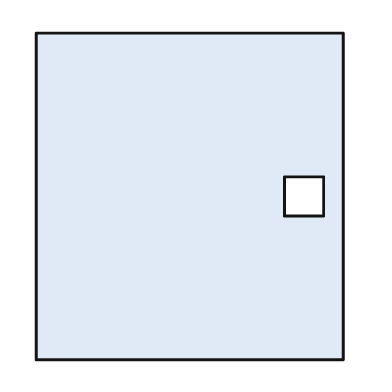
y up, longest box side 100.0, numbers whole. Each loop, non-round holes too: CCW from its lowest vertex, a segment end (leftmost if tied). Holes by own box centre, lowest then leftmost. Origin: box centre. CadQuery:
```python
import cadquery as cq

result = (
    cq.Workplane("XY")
    .moveTo(-47.0, -50.0)
    .lineTo(47.0, -50.0)
    .lineTo(47.0, 50.0)
    .lineTo(-47.0, 50.0)
    .close()
    .moveTo(29.0, -6.0)
    .lineTo(41.0, -6.0)
    .lineTo(41.0, 6.0)
    .lineTo(29.0, 6.0)
    .close()
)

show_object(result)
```